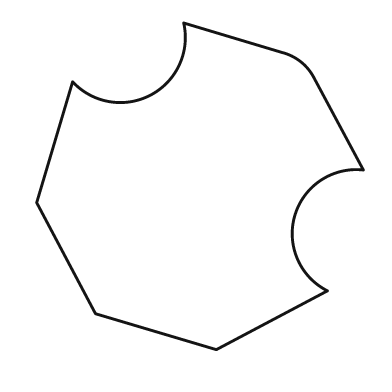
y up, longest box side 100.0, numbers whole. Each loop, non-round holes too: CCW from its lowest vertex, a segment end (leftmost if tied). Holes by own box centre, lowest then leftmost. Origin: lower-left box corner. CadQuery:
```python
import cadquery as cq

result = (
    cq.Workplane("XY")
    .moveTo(55.0, 0.0)
    .lineTo(89.0, 18.0)
    .threePointArc((79.0, 41.0), (100.0, 55.0))
    .lineTo(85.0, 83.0)
    .threePointArc((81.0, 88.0), (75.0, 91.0))
    .lineTo(45.0, 100.0)
    .threePointArc((35.0, 78.0), (11.0, 82.0))
    .lineTo(0.0, 45.0)
    .lineTo(18.0, 11.0)
    .close()
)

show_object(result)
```